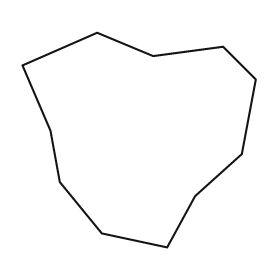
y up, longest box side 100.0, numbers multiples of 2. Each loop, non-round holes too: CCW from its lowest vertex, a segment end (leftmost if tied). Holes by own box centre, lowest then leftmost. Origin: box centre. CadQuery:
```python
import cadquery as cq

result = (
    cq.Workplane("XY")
    .moveTo(12.0, -46.0)
    .lineTo(24.0, -24.0)
    .lineTo(44.0, -6.0)
    .lineTo(50.0, 26.0)
    .lineTo(36.0, 40.0)
    .lineTo(6.0, 36.0)
    .lineTo(-18.0, 46.0)
    .lineTo(-50.0, 32.0)
    .lineTo(-38.0, 4.0)
    .lineTo(-34.0, -18.0)
    .lineTo(-16.0, -40.0)
    .close()
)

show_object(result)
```